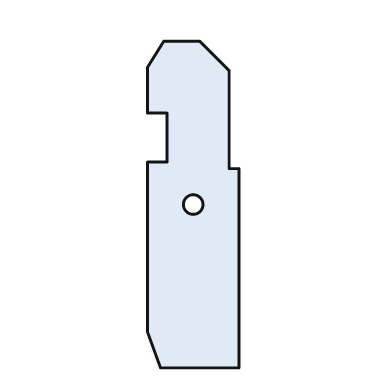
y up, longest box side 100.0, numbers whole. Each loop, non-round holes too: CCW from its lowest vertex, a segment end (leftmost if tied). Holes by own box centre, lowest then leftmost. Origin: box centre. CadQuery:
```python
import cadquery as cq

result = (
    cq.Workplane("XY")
    .moveTo(-10.0, -50.0)
    .lineTo(14.0, -50.0)
    .lineTo(14.0, 11.0)
    .lineTo(11.0, 11.0)
    .lineTo(11.0, 41.0)
    .lineTo(2.0, 50.0)
    .lineTo(-9.0, 50.0)
    .lineTo(-14.0, 42.0)
    .lineTo(-14.0, 28.0)
    .lineTo(-8.0, 28.0)
    .lineTo(-8.0, 13.0)
    .lineTo(-14.0, 13.0)
    .lineTo(-14.0, -39.0)
    .close()
    .moveTo(0.0, 0.0)
    .circle(3.0)
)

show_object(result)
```